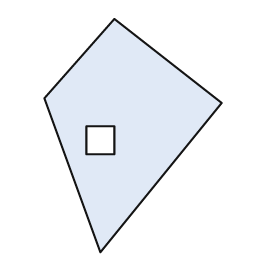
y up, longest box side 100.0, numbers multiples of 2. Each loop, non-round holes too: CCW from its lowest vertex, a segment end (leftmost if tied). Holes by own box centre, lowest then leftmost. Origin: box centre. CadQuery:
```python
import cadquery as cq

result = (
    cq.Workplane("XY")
    .moveTo(-14.0, -50.0)
    .lineTo(38.0, 14.0)
    .lineTo(-8.0, 50.0)
    .lineTo(-38.0, 16.0)
    .close()
    .moveTo(-20.0, -8.0)
    .lineTo(-8.0, -8.0)
    .lineTo(-8.0, 4.0)
    .lineTo(-20.0, 4.0)
    .close()
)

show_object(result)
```